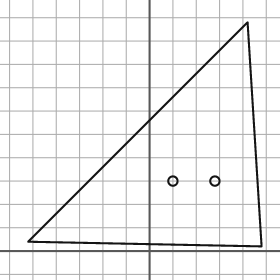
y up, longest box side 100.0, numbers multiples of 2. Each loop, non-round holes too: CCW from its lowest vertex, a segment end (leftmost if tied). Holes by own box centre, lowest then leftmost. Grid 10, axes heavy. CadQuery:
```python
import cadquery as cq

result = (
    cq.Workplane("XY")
    .moveTo(48.0, 2.0)
    .lineTo(42.0, 98.0)
    .lineTo(-52.0, 4.0)
    .close()
    .moveTo(10.0, 30.0)
    .circle(2.0)
    .moveTo(28.0, 30.0)
    .circle(2.0)
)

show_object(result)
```